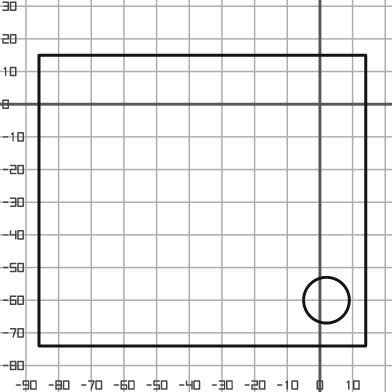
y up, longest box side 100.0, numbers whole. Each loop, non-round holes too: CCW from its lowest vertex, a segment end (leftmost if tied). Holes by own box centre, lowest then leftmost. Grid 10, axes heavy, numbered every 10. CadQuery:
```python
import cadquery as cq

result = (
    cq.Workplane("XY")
    .moveTo(-86.0, -74.0)
    .lineTo(14.0, -74.0)
    .lineTo(14.0, 15.0)
    .lineTo(-86.0, 15.0)
    .close()
    .moveTo(2.0, -60.0)
    .circle(7.0)
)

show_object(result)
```